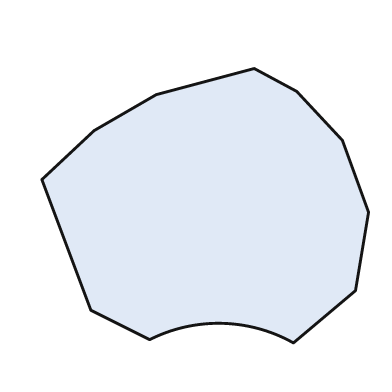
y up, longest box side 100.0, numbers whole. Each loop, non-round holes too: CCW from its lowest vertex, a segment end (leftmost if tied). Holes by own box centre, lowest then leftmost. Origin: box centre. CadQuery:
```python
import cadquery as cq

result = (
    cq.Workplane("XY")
    .moveTo(27.0, -42.0)
    .lineTo(46.0, -26.0)
    .lineTo(50.0, -2.0)
    .lineTo(42.0, 20.0)
    .lineTo(28.0, 35.0)
    .lineTo(15.0, 42.0)
    .lineTo(-15.0, 34.0)
    .lineTo(-34.0, 23.0)
    .lineTo(-50.0, 8.0)
    .lineTo(-35.0, -32.0)
    .lineTo(-17.0, -41.0)
    .threePointArc((5.0, -36.0), (27.0, -42.0))
    .close()
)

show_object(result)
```